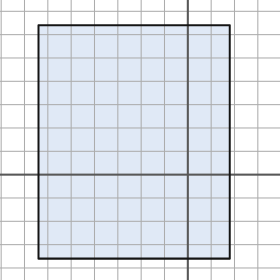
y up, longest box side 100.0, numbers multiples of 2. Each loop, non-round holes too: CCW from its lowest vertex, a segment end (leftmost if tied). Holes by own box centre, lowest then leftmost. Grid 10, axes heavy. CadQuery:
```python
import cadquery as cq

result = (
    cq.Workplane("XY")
    .moveTo(-64.0, -36.0)
    .lineTo(18.0, -36.0)
    .lineTo(18.0, 64.0)
    .lineTo(-64.0, 64.0)
    .close()
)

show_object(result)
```